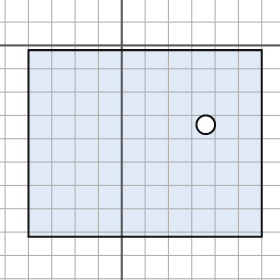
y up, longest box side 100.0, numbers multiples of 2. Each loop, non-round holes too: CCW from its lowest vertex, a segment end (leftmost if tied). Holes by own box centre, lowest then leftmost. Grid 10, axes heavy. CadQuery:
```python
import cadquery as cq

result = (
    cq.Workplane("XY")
    .moveTo(-40.0, -82.0)
    .lineTo(60.0, -82.0)
    .lineTo(60.0, -2.0)
    .lineTo(-40.0, -2.0)
    .close()
    .moveTo(36.0, -34.0)
    .circle(4.0)
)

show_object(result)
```